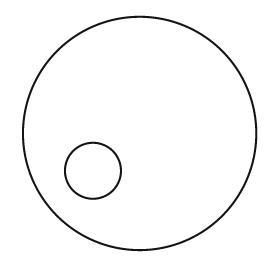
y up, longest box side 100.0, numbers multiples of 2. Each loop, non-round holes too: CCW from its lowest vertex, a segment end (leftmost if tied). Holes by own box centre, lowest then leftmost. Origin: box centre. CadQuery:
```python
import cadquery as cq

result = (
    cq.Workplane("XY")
    .moveTo(0.0, 0.0)
    .circle(50.0)
    .moveTo(-20.0, -16.0)
    .circle(12.0)
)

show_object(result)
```